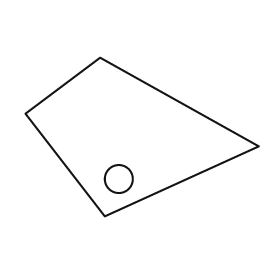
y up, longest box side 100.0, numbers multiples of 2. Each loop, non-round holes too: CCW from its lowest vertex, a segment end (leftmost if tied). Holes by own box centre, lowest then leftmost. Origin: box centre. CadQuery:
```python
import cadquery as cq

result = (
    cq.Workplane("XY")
    .moveTo(-16.0, -34.0)
    .lineTo(50.0, -4.0)
    .lineTo(-18.0, 34.0)
    .lineTo(-50.0, 10.0)
    .close()
    .moveTo(-10.0, -18.0)
    .circle(6.0)
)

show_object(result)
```